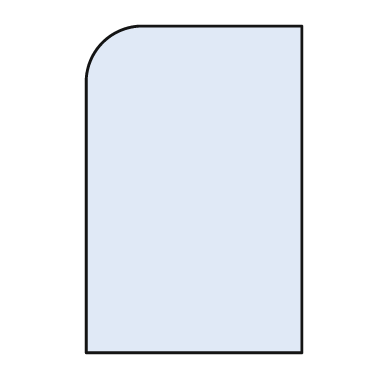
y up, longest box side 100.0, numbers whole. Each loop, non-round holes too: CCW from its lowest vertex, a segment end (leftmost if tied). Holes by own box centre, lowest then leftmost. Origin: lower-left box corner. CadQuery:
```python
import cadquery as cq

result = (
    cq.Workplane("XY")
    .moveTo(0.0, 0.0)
    .lineTo(66.0, 0.0)
    .lineTo(66.0, 100.0)
    .lineTo(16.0, 100.0)
    .threePointArc((5.0, 95.0), (0.0, 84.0))
    .close()
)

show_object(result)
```